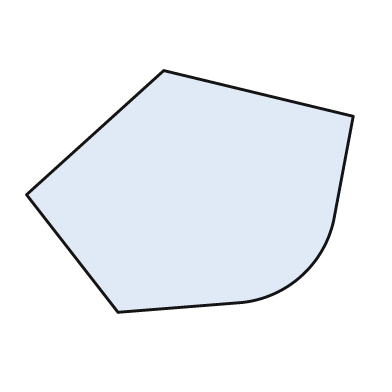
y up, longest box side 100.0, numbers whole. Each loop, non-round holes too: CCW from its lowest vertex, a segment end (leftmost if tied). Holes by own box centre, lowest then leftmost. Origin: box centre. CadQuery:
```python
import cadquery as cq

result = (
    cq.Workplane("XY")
    .moveTo(-22.0, -37.0)
    .lineTo(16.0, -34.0)
    .threePointArc((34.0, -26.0), (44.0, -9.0))
    .lineTo(50.0, 23.0)
    .lineTo(-8.0, 37.0)
    .lineTo(-50.0, -1.0)
    .close()
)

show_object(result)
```